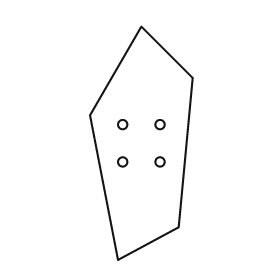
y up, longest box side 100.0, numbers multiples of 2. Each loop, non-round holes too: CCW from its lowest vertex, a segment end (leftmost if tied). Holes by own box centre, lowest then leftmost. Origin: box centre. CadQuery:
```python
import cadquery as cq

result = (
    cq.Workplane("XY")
    .moveTo(-10.0, -50.0)
    .lineTo(16.0, -36.0)
    .lineTo(22.0, 28.0)
    .lineTo(0.0, 50.0)
    .lineTo(-22.0, 12.0)
    .close()
    .moveTo(-8.0, -8.0)
    .circle(2.0)
    .moveTo(8.0, -8.0)
    .circle(2.0)
    .moveTo(-8.0, 8.0)
    .circle(2.0)
    .moveTo(8.0, 8.0)
    .circle(2.0)
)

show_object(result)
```